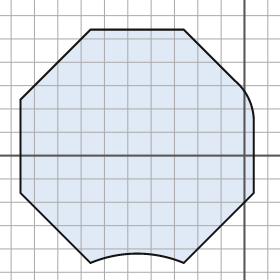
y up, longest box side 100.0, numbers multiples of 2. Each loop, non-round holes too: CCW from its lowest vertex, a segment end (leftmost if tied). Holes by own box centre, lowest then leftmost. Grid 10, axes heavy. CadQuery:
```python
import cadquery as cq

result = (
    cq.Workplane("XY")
    .moveTo(-66.0, -46.0)
    .threePointArc((-46.0, -42.0), (-26.0, -46.0))
    .lineTo(4.0, -16.0)
    .lineTo(4.0, 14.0)
    .threePointArc((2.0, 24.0), (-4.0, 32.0))
    .lineTo(-26.0, 54.0)
    .lineTo(-66.0, 54.0)
    .lineTo(-96.0, 24.0)
    .lineTo(-96.0, -16.0)
    .close()
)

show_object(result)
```